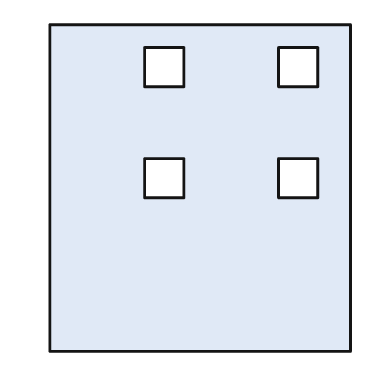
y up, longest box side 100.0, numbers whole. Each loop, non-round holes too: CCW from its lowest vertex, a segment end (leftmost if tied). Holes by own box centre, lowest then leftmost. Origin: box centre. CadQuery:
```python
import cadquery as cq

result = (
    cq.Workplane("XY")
    .moveTo(-46.0, -50.0)
    .lineTo(46.0, -50.0)
    .lineTo(46.0, 50.0)
    .lineTo(-46.0, 50.0)
    .close()
    .moveTo(-17.0, -3.0)
    .lineTo(-5.0, -3.0)
    .lineTo(-5.0, 9.0)
    .lineTo(-17.0, 9.0)
    .close()
    .moveTo(24.0, -3.0)
    .lineTo(36.0, -3.0)
    .lineTo(36.0, 9.0)
    .lineTo(24.0, 9.0)
    .close()
    .moveTo(-17.0, 31.0)
    .lineTo(-5.0, 31.0)
    .lineTo(-5.0, 43.0)
    .lineTo(-17.0, 43.0)
    .close()
    .moveTo(24.0, 31.0)
    .lineTo(36.0, 31.0)
    .lineTo(36.0, 43.0)
    .lineTo(24.0, 43.0)
    .close()
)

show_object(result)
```